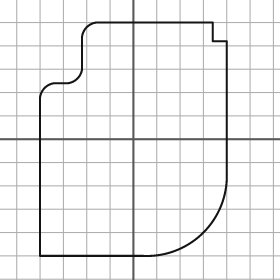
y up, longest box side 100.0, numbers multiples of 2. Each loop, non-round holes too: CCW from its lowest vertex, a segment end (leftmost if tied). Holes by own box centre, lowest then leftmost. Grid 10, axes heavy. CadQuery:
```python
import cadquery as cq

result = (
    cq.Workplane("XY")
    .moveTo(-40.0, -50.0)
    .lineTo(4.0, -50.0)
    .threePointArc((30.0, -40.0), (40.0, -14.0))
    .lineTo(40.0, 42.0)
    .lineTo(34.0, 42.0)
    .lineTo(34.0, 50.0)
    .lineTo(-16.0, 50.0)
    .threePointArc((-20.0, 48.0), (-22.0, 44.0))
    .lineTo(-22.0, 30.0)
    .threePointArc((-24.0, 26.0), (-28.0, 24.0))
    .lineTo(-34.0, 24.0)
    .threePointArc((-38.0, 22.0), (-40.0, 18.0))
    .close()
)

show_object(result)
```